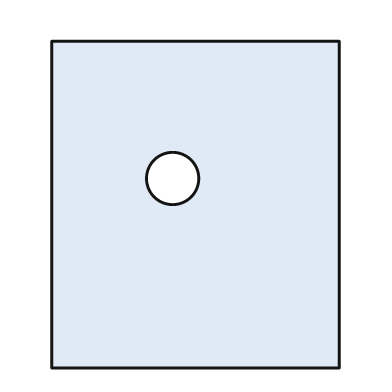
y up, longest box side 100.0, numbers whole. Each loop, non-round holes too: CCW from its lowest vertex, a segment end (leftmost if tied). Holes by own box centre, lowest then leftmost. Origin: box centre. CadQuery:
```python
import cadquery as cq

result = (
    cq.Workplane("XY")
    .moveTo(-44.0, -50.0)
    .lineTo(44.0, -50.0)
    .lineTo(44.0, 50.0)
    .lineTo(-44.0, 50.0)
    .close()
    .moveTo(-7.0, 8.0)
    .circle(8.0)
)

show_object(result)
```